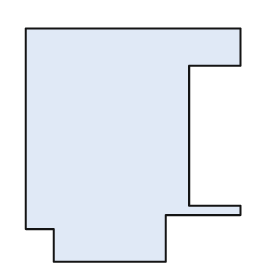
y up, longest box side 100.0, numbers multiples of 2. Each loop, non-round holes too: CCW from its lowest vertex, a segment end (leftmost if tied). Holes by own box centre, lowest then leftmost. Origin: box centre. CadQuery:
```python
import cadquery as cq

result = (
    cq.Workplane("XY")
    .moveTo(-34.0, -50.0)
    .lineTo(14.0, -50.0)
    .lineTo(14.0, -30.0)
    .lineTo(46.0, -30.0)
    .lineTo(46.0, -26.0)
    .lineTo(24.0, -26.0)
    .lineTo(24.0, 34.0)
    .lineTo(46.0, 34.0)
    .lineTo(46.0, 50.0)
    .lineTo(-46.0, 50.0)
    .lineTo(-46.0, -36.0)
    .lineTo(-34.0, -36.0)
    .close()
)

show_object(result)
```